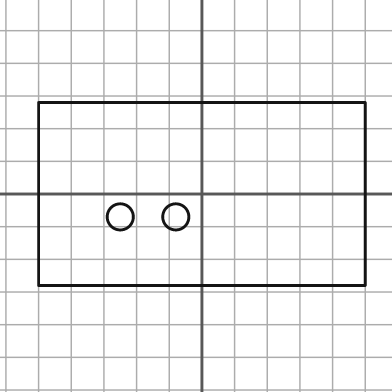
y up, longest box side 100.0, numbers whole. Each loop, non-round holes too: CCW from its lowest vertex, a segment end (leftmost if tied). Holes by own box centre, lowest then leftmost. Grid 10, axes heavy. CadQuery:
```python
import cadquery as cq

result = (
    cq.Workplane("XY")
    .moveTo(-50.0, -28.0)
    .lineTo(50.0, -28.0)
    .lineTo(50.0, 28.0)
    .lineTo(-50.0, 28.0)
    .close()
    .moveTo(-25.0, -7.0)
    .circle(4.0)
    .moveTo(-8.0, -7.0)
    .circle(4.0)
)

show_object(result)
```